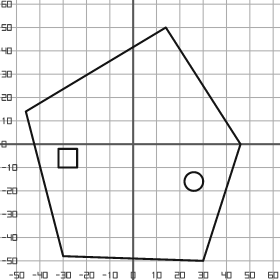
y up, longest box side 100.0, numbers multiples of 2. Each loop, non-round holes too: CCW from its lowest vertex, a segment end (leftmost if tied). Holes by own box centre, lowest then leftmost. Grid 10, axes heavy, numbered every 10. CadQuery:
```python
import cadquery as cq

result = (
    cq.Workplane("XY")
    .moveTo(30.0, -50.0)
    .lineTo(46.0, 0.0)
    .lineTo(14.0, 50.0)
    .lineTo(-46.0, 14.0)
    .lineTo(-30.0, -48.0)
    .close()
    .moveTo(26.0, -16.0)
    .circle(4.0)
    .moveTo(-32.0, -10.0)
    .lineTo(-24.0, -10.0)
    .lineTo(-24.0, -2.0)
    .lineTo(-32.0, -2.0)
    .close()
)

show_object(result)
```